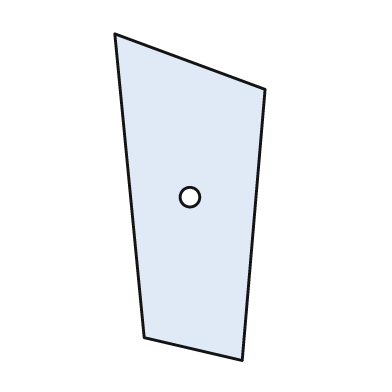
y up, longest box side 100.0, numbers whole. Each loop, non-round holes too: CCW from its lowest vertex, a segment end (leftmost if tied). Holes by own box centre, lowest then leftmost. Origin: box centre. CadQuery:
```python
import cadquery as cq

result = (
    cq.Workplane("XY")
    .moveTo(16.0, -50.0)
    .lineTo(23.0, 33.0)
    .lineTo(-23.0, 50.0)
    .lineTo(-14.0, -43.0)
    .close()
    .moveTo(0.0, 0.0)
    .circle(3.0)
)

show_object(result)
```